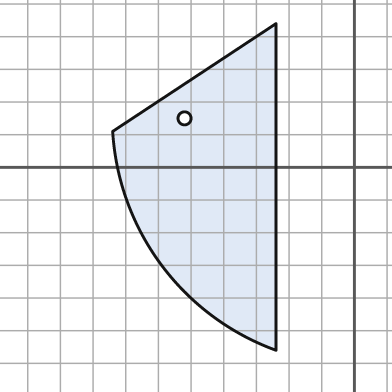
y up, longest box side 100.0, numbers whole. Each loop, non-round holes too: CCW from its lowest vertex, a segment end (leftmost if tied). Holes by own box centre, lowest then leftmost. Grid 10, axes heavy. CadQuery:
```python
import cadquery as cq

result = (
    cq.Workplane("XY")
    .moveTo(-24.0, -56.0)
    .lineTo(-24.0, 44.0)
    .lineTo(-74.0, 11.0)
    .threePointArc((-59.0, -30.0), (-24.0, -56.0))
    .close()
    .moveTo(-52.0, 15.0)
    .circle(2.0)
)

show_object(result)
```